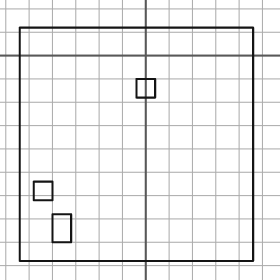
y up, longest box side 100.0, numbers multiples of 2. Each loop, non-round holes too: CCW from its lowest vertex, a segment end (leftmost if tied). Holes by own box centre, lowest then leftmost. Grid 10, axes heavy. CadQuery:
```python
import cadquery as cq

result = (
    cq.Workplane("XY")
    .moveTo(-54.0, -88.0)
    .lineTo(46.0, -88.0)
    .lineTo(46.0, 12.0)
    .lineTo(-54.0, 12.0)
    .close()
    .moveTo(-40.0, -80.0)
    .lineTo(-32.0, -80.0)
    .lineTo(-32.0, -68.0)
    .lineTo(-40.0, -68.0)
    .close()
    .moveTo(-48.0, -62.0)
    .lineTo(-40.0, -62.0)
    .lineTo(-40.0, -54.0)
    .lineTo(-48.0, -54.0)
    .close()
    .moveTo(-4.0, -18.0)
    .lineTo(4.0, -18.0)
    .lineTo(4.0, -10.0)
    .lineTo(-4.0, -10.0)
    .close()
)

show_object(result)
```